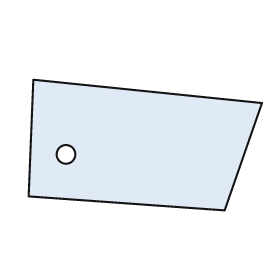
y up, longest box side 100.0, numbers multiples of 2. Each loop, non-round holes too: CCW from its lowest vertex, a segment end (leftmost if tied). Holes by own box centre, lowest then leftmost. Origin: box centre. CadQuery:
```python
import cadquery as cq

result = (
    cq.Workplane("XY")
    .moveTo(34.0, -28.0)
    .lineTo(50.0, 18.0)
    .lineTo(-48.0, 28.0)
    .lineTo(-50.0, -22.0)
    .close()
    .moveTo(-34.0, -4.0)
    .circle(4.0)
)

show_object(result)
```